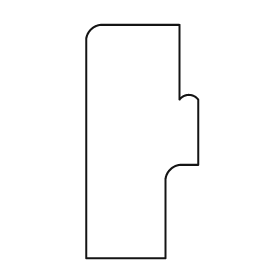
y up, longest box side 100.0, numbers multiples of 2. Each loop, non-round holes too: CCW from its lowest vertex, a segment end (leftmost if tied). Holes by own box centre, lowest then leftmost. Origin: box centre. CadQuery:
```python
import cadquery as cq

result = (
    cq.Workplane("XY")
    .moveTo(-24.0, -50.0)
    .lineTo(10.0, -50.0)
    .lineTo(10.0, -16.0)
    .threePointArc((12.0, -12.0), (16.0, -10.0))
    .lineTo(24.0, -10.0)
    .lineTo(24.0, 18.0)
    .threePointArc((20.0, 20.0), (16.0, 18.0))
    .lineTo(16.0, 50.0)
    .lineTo(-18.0, 50.0)
    .threePointArc((-22.0, 48.0), (-24.0, 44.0))
    .close()
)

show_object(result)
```